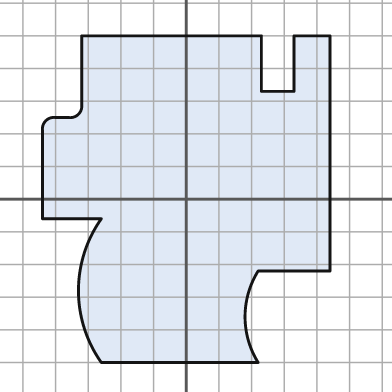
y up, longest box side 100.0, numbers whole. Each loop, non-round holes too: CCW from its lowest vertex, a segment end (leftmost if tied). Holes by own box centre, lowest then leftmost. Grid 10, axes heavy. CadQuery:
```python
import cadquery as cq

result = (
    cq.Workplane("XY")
    .moveTo(-26.0, -50.0)
    .lineTo(22.0, -50.0)
    .threePointArc((18.0, -36.0), (22.0, -22.0))
    .lineTo(44.0, -22.0)
    .lineTo(44.0, 50.0)
    .lineTo(33.0, 50.0)
    .lineTo(33.0, 33.0)
    .lineTo(23.0, 33.0)
    .lineTo(23.0, 50.0)
    .lineTo(-32.0, 50.0)
    .lineTo(-32.0, 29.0)
    .threePointArc((-33.0, 26.0), (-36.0, 25.0))
    .lineTo(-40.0, 25.0)
    .threePointArc((-43.0, 24.0), (-44.0, 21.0))
    .lineTo(-44.0, -6.0)
    .lineTo(-26.0, -6.0)
    .threePointArc((-33.0, -28.0), (-26.0, -50.0))
    .close()
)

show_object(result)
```